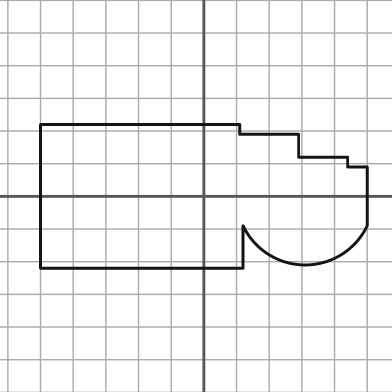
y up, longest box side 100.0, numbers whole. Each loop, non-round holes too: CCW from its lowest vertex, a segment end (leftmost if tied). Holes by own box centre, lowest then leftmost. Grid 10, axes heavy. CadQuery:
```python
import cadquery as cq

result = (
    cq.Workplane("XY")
    .moveTo(-50.0, -22.0)
    .lineTo(12.0, -22.0)
    .lineTo(12.0, -9.0)
    .threePointArc((31.0, -21.0), (50.0, -9.0))
    .lineTo(50.0, 9.0)
    .lineTo(44.0, 9.0)
    .lineTo(44.0, 12.0)
    .lineTo(29.0, 12.0)
    .lineTo(29.0, 19.0)
    .lineTo(11.0, 19.0)
    .lineTo(11.0, 22.0)
    .lineTo(-50.0, 22.0)
    .close()
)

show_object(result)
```